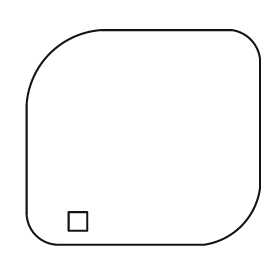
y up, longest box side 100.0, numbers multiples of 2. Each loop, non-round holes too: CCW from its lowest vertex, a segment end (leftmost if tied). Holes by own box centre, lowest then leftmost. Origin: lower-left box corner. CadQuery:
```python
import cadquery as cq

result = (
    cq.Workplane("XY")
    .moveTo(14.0, 0.0)
    .lineTo(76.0, 0.0)
    .threePointArc((92.0, 8.0), (100.0, 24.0))
    .lineTo(100.0, 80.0)
    .threePointArc((96.0, 88.0), (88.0, 92.0))
    .lineTo(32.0, 92.0)
    .threePointArc((10.0, 82.0), (0.0, 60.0))
    .lineTo(0.0, 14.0)
    .threePointArc((4.0, 4.0), (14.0, 0.0))
    .close()
    .moveTo(18.0, 6.0)
    .lineTo(26.0, 6.0)
    .lineTo(26.0, 14.0)
    .lineTo(18.0, 14.0)
    .close()
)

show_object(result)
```